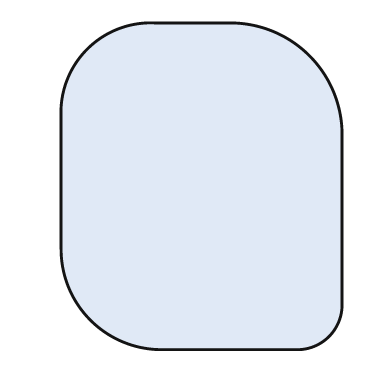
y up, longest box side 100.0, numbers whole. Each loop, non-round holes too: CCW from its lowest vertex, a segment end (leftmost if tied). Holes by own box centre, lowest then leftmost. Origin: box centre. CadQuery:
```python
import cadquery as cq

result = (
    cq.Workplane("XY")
    .moveTo(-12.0, -50.0)
    .lineTo(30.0, -50.0)
    .threePointArc((39.0, -46.0), (43.0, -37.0))
    .lineTo(43.0, 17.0)
    .threePointArc((33.0, 40.0), (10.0, 50.0))
    .lineTo(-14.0, 50.0)
    .threePointArc((-35.0, 42.0), (-43.0, 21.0))
    .lineTo(-43.0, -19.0)
    .threePointArc((-34.0, -41.0), (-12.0, -50.0))
    .close()
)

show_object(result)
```